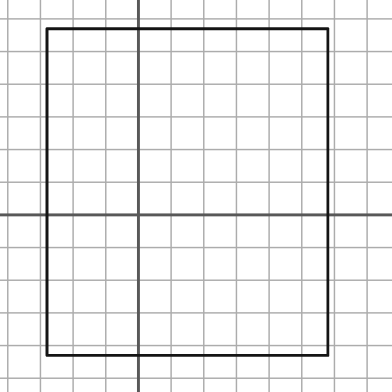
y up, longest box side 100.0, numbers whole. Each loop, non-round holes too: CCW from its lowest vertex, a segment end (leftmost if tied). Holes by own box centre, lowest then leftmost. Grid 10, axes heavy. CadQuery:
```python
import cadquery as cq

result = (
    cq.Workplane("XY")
    .moveTo(-28.0, -43.0)
    .lineTo(58.0, -43.0)
    .lineTo(58.0, 57.0)
    .lineTo(-28.0, 57.0)
    .close()
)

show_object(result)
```